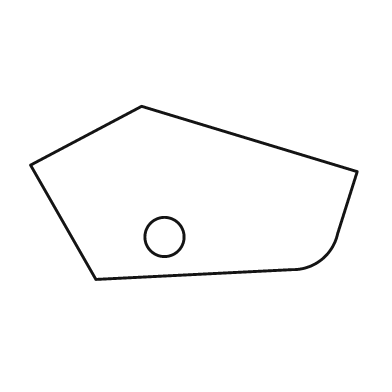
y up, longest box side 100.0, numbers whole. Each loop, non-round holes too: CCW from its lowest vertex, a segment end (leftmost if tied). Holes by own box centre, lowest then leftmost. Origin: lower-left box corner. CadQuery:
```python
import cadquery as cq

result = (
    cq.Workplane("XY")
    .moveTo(20.0, 0.0)
    .lineTo(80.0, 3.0)
    .threePointArc((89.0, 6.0), (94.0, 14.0))
    .lineTo(100.0, 33.0)
    .lineTo(34.0, 53.0)
    .lineTo(0.0, 35.0)
    .close()
    .moveTo(41.0, 13.0)
    .circle(6.0)
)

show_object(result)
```